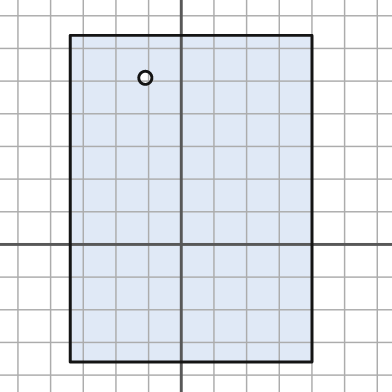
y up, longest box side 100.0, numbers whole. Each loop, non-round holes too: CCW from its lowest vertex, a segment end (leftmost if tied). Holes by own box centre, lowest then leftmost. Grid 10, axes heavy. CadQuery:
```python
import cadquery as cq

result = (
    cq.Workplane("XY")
    .moveTo(-34.0, -36.0)
    .lineTo(40.0, -36.0)
    .lineTo(40.0, 64.0)
    .lineTo(-34.0, 64.0)
    .close()
    .moveTo(-11.0, 51.0)
    .circle(2.0)
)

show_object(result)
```